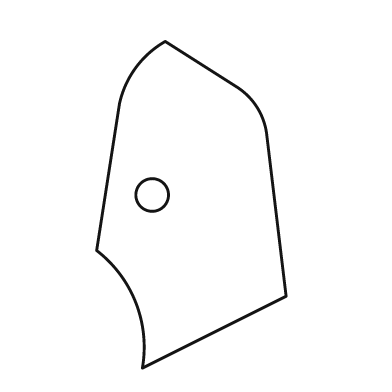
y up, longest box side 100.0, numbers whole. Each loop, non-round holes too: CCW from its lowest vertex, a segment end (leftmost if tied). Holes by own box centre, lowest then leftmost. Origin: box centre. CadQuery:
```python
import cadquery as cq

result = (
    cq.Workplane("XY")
    .moveTo(-15.0, -50.0)
    .lineTo(29.0, -28.0)
    .lineTo(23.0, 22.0)
    .threePointArc((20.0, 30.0), (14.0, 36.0))
    .lineTo(-8.0, 50.0)
    .threePointArc((-17.0, 42.0), (-22.0, 31.0))
    .lineTo(-29.0, -14.0)
    .threePointArc((-17.0, -30.0), (-15.0, -50.0))
    .close()
    .moveTo(-12.0, 3.0)
    .circle(5.0)
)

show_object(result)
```